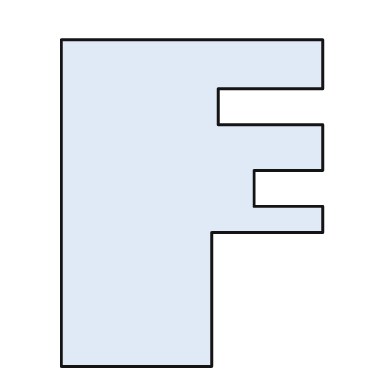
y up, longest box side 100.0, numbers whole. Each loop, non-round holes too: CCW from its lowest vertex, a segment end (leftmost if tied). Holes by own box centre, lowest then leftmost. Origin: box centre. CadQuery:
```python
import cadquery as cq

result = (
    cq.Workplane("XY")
    .moveTo(-40.0, -50.0)
    .lineTo(6.0, -50.0)
    .lineTo(6.0, -9.0)
    .lineTo(40.0, -9.0)
    .lineTo(40.0, -1.0)
    .lineTo(19.0, -1.0)
    .lineTo(19.0, 10.0)
    .lineTo(40.0, 10.0)
    .lineTo(40.0, 24.0)
    .lineTo(8.0, 24.0)
    .lineTo(8.0, 35.0)
    .lineTo(40.0, 35.0)
    .lineTo(40.0, 50.0)
    .lineTo(-40.0, 50.0)
    .close()
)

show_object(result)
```